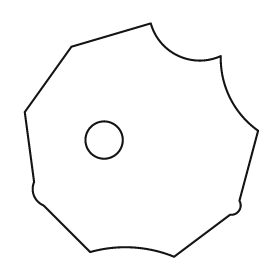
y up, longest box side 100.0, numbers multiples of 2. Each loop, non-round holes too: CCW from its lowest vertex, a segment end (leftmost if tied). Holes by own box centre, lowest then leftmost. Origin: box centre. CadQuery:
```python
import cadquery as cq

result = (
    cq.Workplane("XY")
    .moveTo(14.0, -50.0)
    .lineTo(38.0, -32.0)
    .threePointArc((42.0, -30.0), (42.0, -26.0))
    .lineTo(50.0, 4.0)
    .threePointArc((38.0, 18.0), (34.0, 36.0))
    .threePointArc((16.0, 36.0), (4.0, 50.0))
    .lineTo(-30.0, 40.0)
    .lineTo(-50.0, 12.0)
    .lineTo(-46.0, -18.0)
    .threePointArc((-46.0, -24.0), (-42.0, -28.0))
    .lineTo(-22.0, -48.0)
    .threePointArc((-4.0, -46.0), (14.0, -50.0))
    .close()
    .moveTo(-16.0, 0.0)
    .circle(8.0)
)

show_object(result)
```